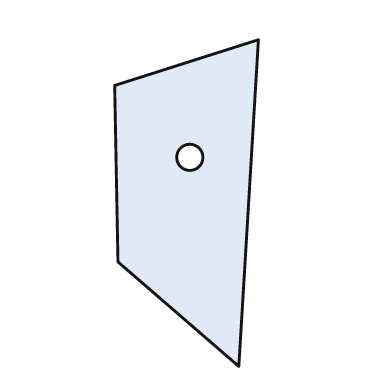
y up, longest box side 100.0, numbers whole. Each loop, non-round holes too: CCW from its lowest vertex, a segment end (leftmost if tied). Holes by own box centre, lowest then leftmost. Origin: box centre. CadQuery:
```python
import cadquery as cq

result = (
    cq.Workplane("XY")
    .moveTo(16.0, -50.0)
    .lineTo(22.0, 50.0)
    .lineTo(-22.0, 36.0)
    .lineTo(-21.0, -18.0)
    .close()
    .moveTo(1.0, 14.0)
    .circle(4.0)
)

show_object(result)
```